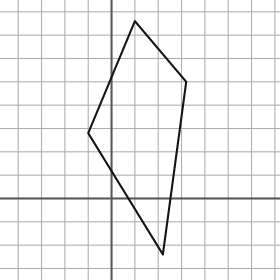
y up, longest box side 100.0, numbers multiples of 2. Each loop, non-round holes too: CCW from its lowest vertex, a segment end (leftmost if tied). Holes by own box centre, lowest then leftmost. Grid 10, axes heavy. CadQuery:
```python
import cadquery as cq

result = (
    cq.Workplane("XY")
    .moveTo(22.0, -24.0)
    .lineTo(32.0, 50.0)
    .lineTo(10.0, 76.0)
    .lineTo(-10.0, 28.0)
    .close()
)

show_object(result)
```